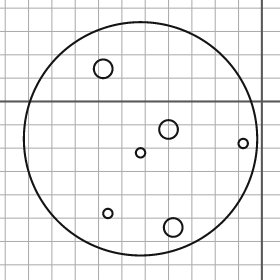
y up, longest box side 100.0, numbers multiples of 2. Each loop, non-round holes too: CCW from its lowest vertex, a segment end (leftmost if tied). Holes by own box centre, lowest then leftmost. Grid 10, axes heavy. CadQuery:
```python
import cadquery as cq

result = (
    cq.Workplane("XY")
    .moveTo(-52.0, -16.0)
    .circle(50.0)
    .moveTo(-38.0, -54.0)
    .circle(4.0)
    .moveTo(-66.0, -48.0)
    .circle(2.0)
    .moveTo(-52.0, -22.0)
    .circle(2.0)
    .moveTo(-8.0, -18.0)
    .circle(2.0)
    .moveTo(-40.0, -12.0)
    .circle(4.0)
    .moveTo(-68.0, 14.0)
    .circle(4.0)
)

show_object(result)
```